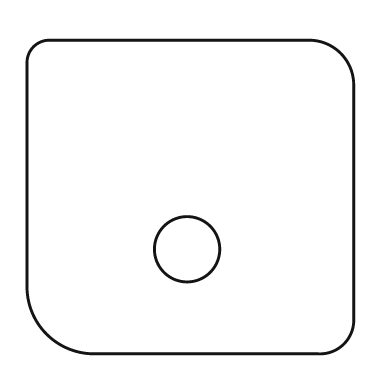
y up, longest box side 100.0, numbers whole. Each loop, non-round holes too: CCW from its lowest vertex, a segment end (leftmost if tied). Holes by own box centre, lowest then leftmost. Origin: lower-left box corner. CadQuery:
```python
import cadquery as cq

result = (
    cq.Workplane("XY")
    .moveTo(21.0, 0.0)
    .lineTo(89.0, 0.0)
    .threePointArc((97.0, 3.0), (100.0, 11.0))
    .lineTo(100.0, 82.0)
    .threePointArc((96.0, 92.0), (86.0, 96.0))
    .lineTo(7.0, 96.0)
    .threePointArc((2.0, 94.0), (0.0, 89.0))
    .lineTo(0.0, 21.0)
    .threePointArc((6.0, 6.0), (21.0, 0.0))
    .close()
    .moveTo(49.0, 32.0)
    .circle(10.0)
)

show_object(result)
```